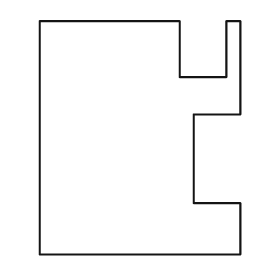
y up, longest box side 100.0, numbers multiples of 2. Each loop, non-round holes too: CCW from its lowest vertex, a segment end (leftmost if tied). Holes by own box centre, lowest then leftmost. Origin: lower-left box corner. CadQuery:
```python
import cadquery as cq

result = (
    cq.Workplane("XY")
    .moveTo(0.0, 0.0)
    .lineTo(86.0, 0.0)
    .lineTo(86.0, 22.0)
    .lineTo(66.0, 22.0)
    .lineTo(66.0, 60.0)
    .lineTo(86.0, 60.0)
    .lineTo(86.0, 100.0)
    .lineTo(80.0, 100.0)
    .lineTo(80.0, 76.0)
    .lineTo(60.0, 76.0)
    .lineTo(60.0, 100.0)
    .lineTo(0.0, 100.0)
    .close()
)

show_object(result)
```